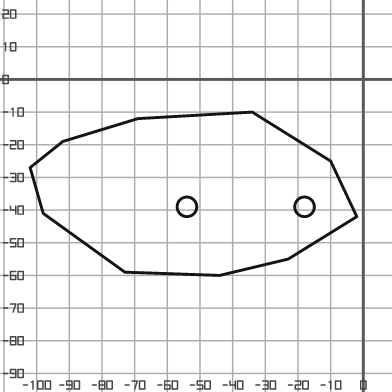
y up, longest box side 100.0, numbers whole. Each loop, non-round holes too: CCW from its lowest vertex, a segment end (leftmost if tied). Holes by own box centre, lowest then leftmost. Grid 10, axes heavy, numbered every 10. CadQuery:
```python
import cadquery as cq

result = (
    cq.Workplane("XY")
    .moveTo(-44.0, -60.0)
    .lineTo(-23.0, -55.0)
    .lineTo(-2.0, -42.0)
    .lineTo(-10.0, -25.0)
    .lineTo(-34.0, -10.0)
    .lineTo(-69.0, -12.0)
    .lineTo(-92.0, -19.0)
    .lineTo(-102.0, -27.0)
    .lineTo(-98.0, -41.0)
    .lineTo(-73.0, -59.0)
    .close()
    .moveTo(-54.0, -39.0)
    .circle(3.0)
    .moveTo(-18.0, -39.0)
    .circle(3.0)
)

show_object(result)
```